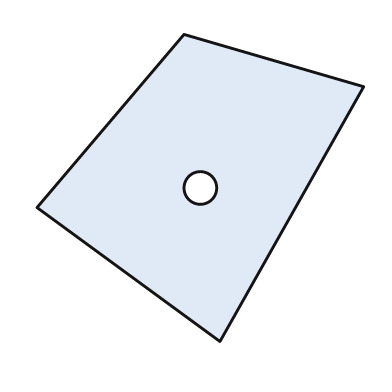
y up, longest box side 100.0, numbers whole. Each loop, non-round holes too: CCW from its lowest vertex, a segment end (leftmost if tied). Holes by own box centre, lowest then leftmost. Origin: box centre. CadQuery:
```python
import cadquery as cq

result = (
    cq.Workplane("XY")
    .moveTo(6.0, -47.0)
    .lineTo(50.0, 31.0)
    .lineTo(-5.0, 47.0)
    .lineTo(-50.0, -6.0)
    .close()
    .moveTo(0.0, 0.0)
    .circle(5.0)
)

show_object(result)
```